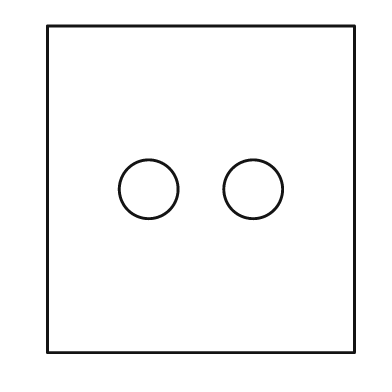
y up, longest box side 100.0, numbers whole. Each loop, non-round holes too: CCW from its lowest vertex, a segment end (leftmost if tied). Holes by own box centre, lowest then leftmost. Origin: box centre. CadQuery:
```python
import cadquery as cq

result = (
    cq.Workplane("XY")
    .moveTo(-47.0, -50.0)
    .lineTo(47.0, -50.0)
    .lineTo(47.0, 50.0)
    .lineTo(-47.0, 50.0)
    .close()
    .moveTo(-16.0, 0.0)
    .circle(9.0)
    .moveTo(16.0, 0.0)
    .circle(9.0)
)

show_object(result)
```